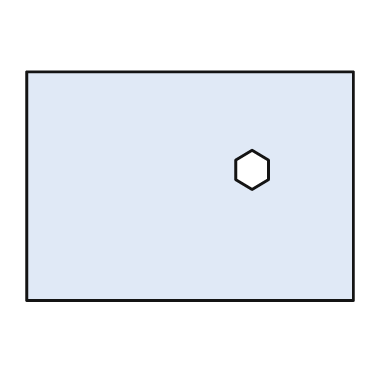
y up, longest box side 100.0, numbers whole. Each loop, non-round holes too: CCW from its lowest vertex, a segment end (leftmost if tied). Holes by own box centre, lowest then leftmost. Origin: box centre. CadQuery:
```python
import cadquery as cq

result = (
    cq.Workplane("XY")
    .moveTo(-50.0, -35.0)
    .lineTo(50.0, -35.0)
    .lineTo(50.0, 35.0)
    .lineTo(-50.0, 35.0)
    .close()
    .moveTo(19.0, -1.0)
    .lineTo(24.0, 2.0)
    .lineTo(24.0, 8.0)
    .lineTo(19.0, 11.0)
    .lineTo(14.0, 8.0)
    .lineTo(14.0, 2.0)
    .close()
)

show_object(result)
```